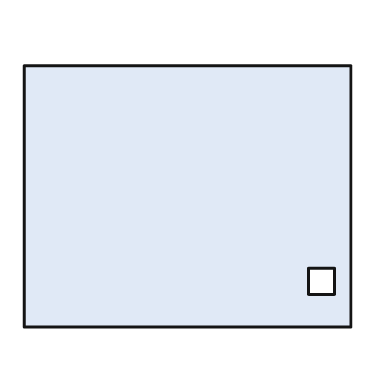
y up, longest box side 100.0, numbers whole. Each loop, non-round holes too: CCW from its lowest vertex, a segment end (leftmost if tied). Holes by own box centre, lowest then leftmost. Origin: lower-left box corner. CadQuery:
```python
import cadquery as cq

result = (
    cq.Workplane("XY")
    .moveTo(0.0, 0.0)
    .lineTo(100.0, 0.0)
    .lineTo(100.0, 80.0)
    .lineTo(0.0, 80.0)
    .close()
    .moveTo(87.0, 10.0)
    .lineTo(95.0, 10.0)
    .lineTo(95.0, 18.0)
    .lineTo(87.0, 18.0)
    .close()
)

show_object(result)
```